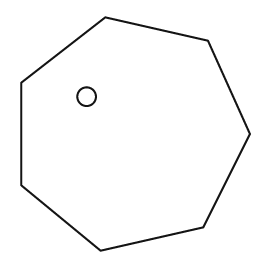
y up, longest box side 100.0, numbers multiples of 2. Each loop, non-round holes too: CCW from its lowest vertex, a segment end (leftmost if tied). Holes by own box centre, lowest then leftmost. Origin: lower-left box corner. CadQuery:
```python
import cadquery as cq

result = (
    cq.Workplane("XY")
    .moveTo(34.0, 0.0)
    .lineTo(78.0, 10.0)
    .lineTo(98.0, 50.0)
    .lineTo(80.0, 90.0)
    .lineTo(36.0, 100.0)
    .lineTo(0.0, 72.0)
    .lineTo(0.0, 28.0)
    .close()
    .moveTo(28.0, 66.0)
    .circle(4.0)
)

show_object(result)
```